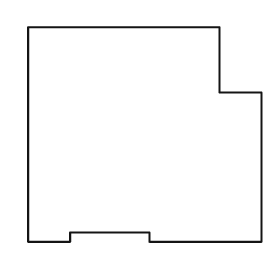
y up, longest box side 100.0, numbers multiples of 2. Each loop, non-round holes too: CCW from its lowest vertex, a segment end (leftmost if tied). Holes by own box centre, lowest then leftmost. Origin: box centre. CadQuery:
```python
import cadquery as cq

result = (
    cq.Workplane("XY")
    .moveTo(-50.0, -46.0)
    .lineTo(-32.0, -46.0)
    .lineTo(-32.0, -42.0)
    .lineTo(2.0, -42.0)
    .lineTo(2.0, -46.0)
    .lineTo(50.0, -46.0)
    .lineTo(50.0, 18.0)
    .lineTo(32.0, 18.0)
    .lineTo(32.0, 46.0)
    .lineTo(-50.0, 46.0)
    .close()
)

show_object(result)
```